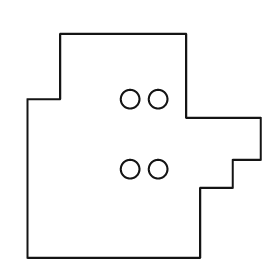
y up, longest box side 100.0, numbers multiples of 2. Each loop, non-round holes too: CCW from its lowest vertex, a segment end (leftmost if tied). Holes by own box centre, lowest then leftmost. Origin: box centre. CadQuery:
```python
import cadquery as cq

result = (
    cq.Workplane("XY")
    .moveTo(-50.0, -48.0)
    .lineTo(24.0, -48.0)
    .lineTo(24.0, -18.0)
    .lineTo(38.0, -18.0)
    .lineTo(38.0, -6.0)
    .lineTo(50.0, -6.0)
    .lineTo(50.0, 12.0)
    .lineTo(18.0, 12.0)
    .lineTo(18.0, 48.0)
    .lineTo(-36.0, 48.0)
    .lineTo(-36.0, 20.0)
    .lineTo(-50.0, 20.0)
    .close()
    .moveTo(-6.0, -10.0)
    .circle(4.0)
    .moveTo(6.0, -10.0)
    .circle(4.0)
    .moveTo(-6.0, 20.0)
    .circle(4.0)
    .moveTo(6.0, 20.0)
    .circle(4.0)
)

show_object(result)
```